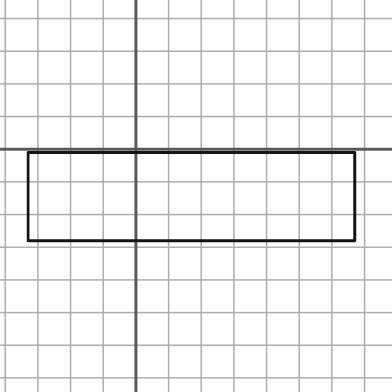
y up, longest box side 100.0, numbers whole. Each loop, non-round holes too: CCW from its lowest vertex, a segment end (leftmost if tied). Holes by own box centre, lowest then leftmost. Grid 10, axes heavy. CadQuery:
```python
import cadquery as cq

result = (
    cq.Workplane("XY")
    .moveTo(-33.0, -28.0)
    .lineTo(67.0, -28.0)
    .lineTo(67.0, -1.0)
    .lineTo(-33.0, -1.0)
    .close()
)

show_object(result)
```